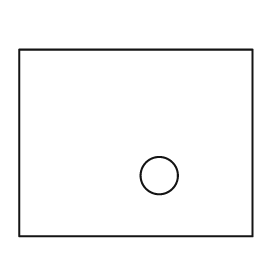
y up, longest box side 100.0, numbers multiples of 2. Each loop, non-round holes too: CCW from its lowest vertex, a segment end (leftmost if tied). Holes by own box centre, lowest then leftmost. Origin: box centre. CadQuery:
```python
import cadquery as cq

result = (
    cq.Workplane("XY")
    .moveTo(-50.0, -40.0)
    .lineTo(50.0, -40.0)
    .lineTo(50.0, 40.0)
    .lineTo(-50.0, 40.0)
    .close()
    .moveTo(10.0, -14.0)
    .circle(8.0)
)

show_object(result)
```